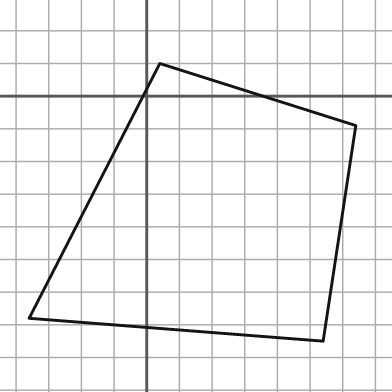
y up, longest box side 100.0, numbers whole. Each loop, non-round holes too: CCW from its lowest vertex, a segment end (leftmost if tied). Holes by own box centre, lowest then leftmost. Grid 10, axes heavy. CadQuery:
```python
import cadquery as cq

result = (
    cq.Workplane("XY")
    .moveTo(54.0, -75.0)
    .lineTo(64.0, -9.0)
    .lineTo(4.0, 10.0)
    .lineTo(-36.0, -68.0)
    .close()
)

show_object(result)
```